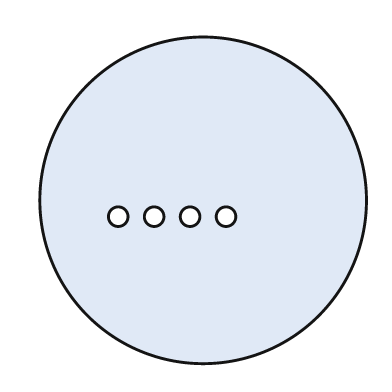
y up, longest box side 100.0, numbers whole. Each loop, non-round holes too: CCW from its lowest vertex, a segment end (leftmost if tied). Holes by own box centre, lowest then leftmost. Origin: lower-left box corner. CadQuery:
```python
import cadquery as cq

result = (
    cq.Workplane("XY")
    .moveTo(50.0, 50.0)
    .circle(50.0)
    .moveTo(24.0, 45.0)
    .circle(3.0)
    .moveTo(35.0, 45.0)
    .circle(3.0)
    .moveTo(46.0, 45.0)
    .circle(3.0)
    .moveTo(57.0, 45.0)
    .circle(3.0)
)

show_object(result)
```